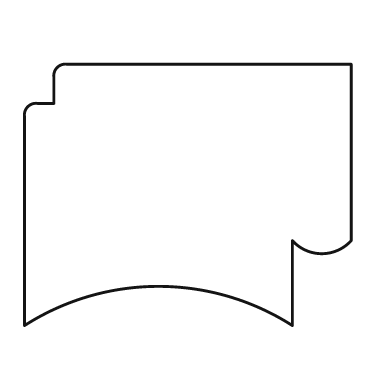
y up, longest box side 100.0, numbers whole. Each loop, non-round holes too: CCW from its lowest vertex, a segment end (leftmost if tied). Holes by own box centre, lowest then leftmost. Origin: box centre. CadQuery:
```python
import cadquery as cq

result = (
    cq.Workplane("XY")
    .moveTo(-50.0, -40.0)
    .threePointArc((-9.0, -28.0), (32.0, -40.0))
    .lineTo(32.0, -14.0)
    .threePointArc((41.0, -18.0), (50.0, -14.0))
    .lineTo(50.0, 40.0)
    .lineTo(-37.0, 40.0)
    .threePointArc((-40.0, 39.0), (-41.0, 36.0))
    .lineTo(-41.0, 28.0)
    .lineTo(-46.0, 28.0)
    .threePointArc((-49.0, 27.0), (-50.0, 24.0))
    .close()
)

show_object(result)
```